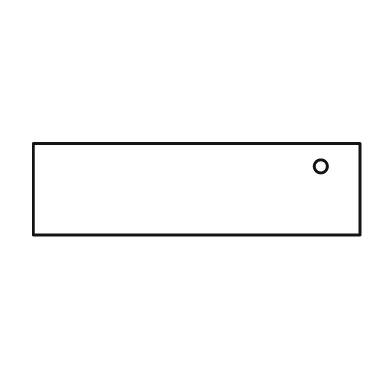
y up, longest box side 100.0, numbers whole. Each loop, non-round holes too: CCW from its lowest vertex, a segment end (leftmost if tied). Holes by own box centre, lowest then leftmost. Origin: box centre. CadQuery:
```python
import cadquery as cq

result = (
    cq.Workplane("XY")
    .moveTo(-50.0, -14.0)
    .lineTo(50.0, -14.0)
    .lineTo(50.0, 14.0)
    .lineTo(-50.0, 14.0)
    .close()
    .moveTo(38.0, 7.0)
    .circle(2.0)
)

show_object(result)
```